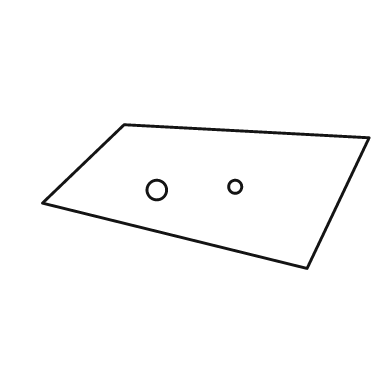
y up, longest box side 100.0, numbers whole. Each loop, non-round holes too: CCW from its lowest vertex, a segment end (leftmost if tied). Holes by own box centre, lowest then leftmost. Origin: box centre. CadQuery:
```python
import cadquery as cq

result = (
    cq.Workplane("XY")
    .moveTo(31.0, -22.0)
    .lineTo(50.0, 18.0)
    .lineTo(-25.0, 22.0)
    .lineTo(-50.0, -2.0)
    .close()
    .moveTo(-15.0, 2.0)
    .circle(3.0)
    .moveTo(9.0, 3.0)
    .circle(2.0)
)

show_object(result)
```